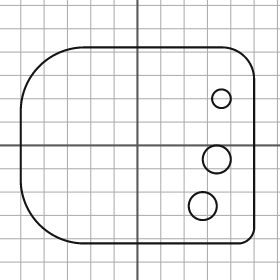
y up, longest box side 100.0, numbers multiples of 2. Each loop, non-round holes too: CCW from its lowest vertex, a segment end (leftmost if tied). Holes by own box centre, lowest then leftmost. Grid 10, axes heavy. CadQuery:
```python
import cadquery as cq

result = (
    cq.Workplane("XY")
    .moveTo(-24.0, -42.0)
    .lineTo(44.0, -42.0)
    .threePointArc((48.0, -40.0), (50.0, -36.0))
    .lineTo(50.0, 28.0)
    .threePointArc((46.0, 38.0), (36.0, 42.0))
    .lineTo(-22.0, 42.0)
    .threePointArc((-42.0, 34.0), (-50.0, 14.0))
    .lineTo(-50.0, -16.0)
    .threePointArc((-42.0, -34.0), (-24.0, -42.0))
    .close()
    .moveTo(28.0, -26.0)
    .circle(6.0)
    .moveTo(34.0, -6.0)
    .circle(6.0)
    .moveTo(36.0, 20.0)
    .circle(4.0)
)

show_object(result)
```